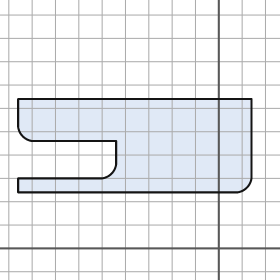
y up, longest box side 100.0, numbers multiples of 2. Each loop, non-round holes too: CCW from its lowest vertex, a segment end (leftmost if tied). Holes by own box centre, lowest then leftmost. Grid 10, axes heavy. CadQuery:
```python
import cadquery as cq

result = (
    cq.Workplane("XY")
    .moveTo(-86.0, 24.0)
    .lineTo(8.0, 24.0)
    .threePointArc((12.0, 26.0), (14.0, 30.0))
    .lineTo(14.0, 64.0)
    .lineTo(-86.0, 64.0)
    .lineTo(-86.0, 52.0)
    .threePointArc((-84.0, 48.0), (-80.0, 46.0))
    .lineTo(-44.0, 46.0)
    .lineTo(-44.0, 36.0)
    .threePointArc((-46.0, 32.0), (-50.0, 30.0))
    .lineTo(-86.0, 30.0)
    .close()
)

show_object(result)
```